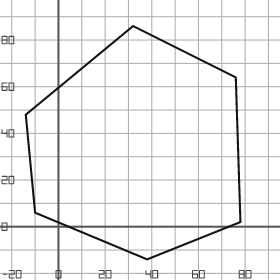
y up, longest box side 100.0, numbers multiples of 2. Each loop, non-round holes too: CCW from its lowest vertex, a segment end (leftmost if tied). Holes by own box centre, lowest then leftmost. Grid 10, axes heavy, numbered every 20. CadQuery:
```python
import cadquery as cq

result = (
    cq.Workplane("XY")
    .moveTo(38.0, -14.0)
    .lineTo(78.0, 2.0)
    .lineTo(76.0, 64.0)
    .lineTo(32.0, 86.0)
    .lineTo(-14.0, 48.0)
    .lineTo(-10.0, 6.0)
    .close()
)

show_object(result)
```